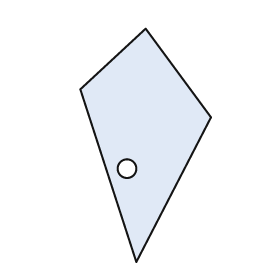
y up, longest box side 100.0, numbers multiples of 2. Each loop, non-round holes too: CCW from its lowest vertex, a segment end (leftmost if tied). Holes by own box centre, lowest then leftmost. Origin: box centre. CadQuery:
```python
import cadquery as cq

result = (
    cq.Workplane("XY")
    .moveTo(-4.0, -50.0)
    .lineTo(28.0, 12.0)
    .lineTo(0.0, 50.0)
    .lineTo(-28.0, 24.0)
    .close()
    .moveTo(-8.0, -10.0)
    .circle(4.0)
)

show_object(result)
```